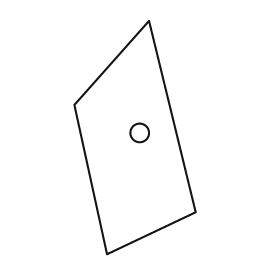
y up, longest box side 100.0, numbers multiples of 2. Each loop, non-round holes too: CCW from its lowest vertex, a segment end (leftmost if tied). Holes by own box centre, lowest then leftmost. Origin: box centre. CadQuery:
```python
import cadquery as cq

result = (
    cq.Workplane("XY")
    .moveTo(-12.0, -50.0)
    .lineTo(26.0, -32.0)
    .lineTo(6.0, 50.0)
    .lineTo(-26.0, 14.0)
    .close()
    .moveTo(2.0, 2.0)
    .circle(4.0)
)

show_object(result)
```